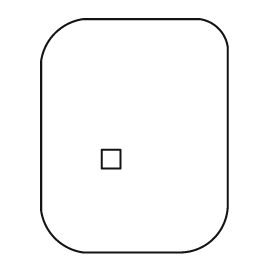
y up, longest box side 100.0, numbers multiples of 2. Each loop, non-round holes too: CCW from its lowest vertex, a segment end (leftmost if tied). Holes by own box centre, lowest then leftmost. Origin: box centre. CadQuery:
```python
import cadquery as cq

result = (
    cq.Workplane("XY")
    .moveTo(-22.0, -50.0)
    .lineTo(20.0, -50.0)
    .threePointArc((34.0, -44.0), (40.0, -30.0))
    .lineTo(40.0, 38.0)
    .threePointArc((36.0, 46.0), (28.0, 50.0))
    .lineTo(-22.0, 50.0)
    .threePointArc((-34.0, 44.0), (-40.0, 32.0))
    .lineTo(-40.0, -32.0)
    .threePointArc((-34.0, -44.0), (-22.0, -50.0))
    .close()
    .moveTo(-14.0, -14.0)
    .lineTo(-6.0, -14.0)
    .lineTo(-6.0, -6.0)
    .lineTo(-14.0, -6.0)
    .close()
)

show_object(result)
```